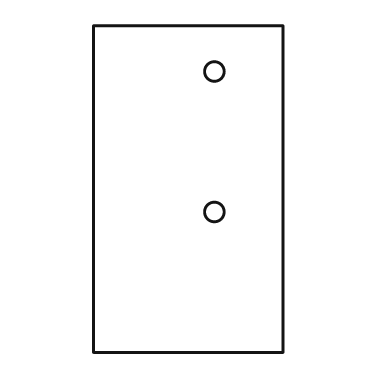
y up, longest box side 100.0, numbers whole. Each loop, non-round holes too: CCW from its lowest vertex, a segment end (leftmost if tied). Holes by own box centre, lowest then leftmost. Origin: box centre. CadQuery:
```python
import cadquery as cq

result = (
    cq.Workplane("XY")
    .moveTo(-29.0, -50.0)
    .lineTo(29.0, -50.0)
    .lineTo(29.0, 50.0)
    .lineTo(-29.0, 50.0)
    .close()
    .moveTo(8.0, -7.0)
    .circle(3.0)
    .moveTo(8.0, 36.0)
    .circle(3.0)
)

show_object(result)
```